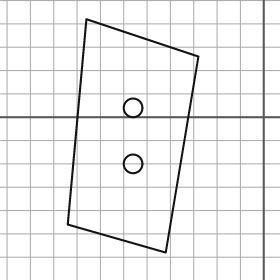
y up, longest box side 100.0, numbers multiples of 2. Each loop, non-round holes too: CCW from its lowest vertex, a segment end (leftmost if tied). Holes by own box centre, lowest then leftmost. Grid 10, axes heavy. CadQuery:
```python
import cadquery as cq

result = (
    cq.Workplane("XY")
    .moveTo(-42.0, -58.0)
    .lineTo(-28.0, 26.0)
    .lineTo(-76.0, 42.0)
    .lineTo(-84.0, -46.0)
    .close()
    .moveTo(-56.0, -20.0)
    .circle(4.0)
    .moveTo(-56.0, 4.0)
    .circle(4.0)
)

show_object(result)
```